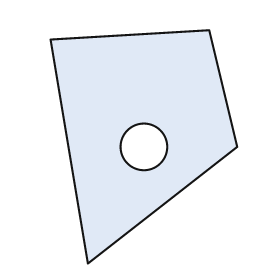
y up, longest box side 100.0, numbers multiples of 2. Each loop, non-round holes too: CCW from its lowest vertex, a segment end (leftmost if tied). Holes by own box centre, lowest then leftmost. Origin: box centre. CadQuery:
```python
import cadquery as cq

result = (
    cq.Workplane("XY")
    .moveTo(-24.0, -50.0)
    .lineTo(40.0, 0.0)
    .lineTo(28.0, 50.0)
    .lineTo(-40.0, 46.0)
    .close()
    .moveTo(0.0, 0.0)
    .circle(10.0)
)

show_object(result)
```